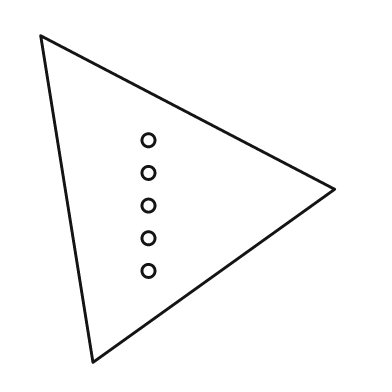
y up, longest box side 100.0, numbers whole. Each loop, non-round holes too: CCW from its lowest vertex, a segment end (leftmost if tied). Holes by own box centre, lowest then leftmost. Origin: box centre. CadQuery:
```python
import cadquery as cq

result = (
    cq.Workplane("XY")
    .moveTo(-29.0, -50.0)
    .lineTo(45.0, 3.0)
    .lineTo(-45.0, 50.0)
    .close()
    .moveTo(-12.0, -22.0)
    .circle(2.0)
    .moveTo(-12.0, -12.0)
    .circle(2.0)
    .moveTo(-12.0, -2.0)
    .circle(2.0)
    .moveTo(-12.0, 8.0)
    .circle(2.0)
    .moveTo(-12.0, 18.0)
    .circle(2.0)
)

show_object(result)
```